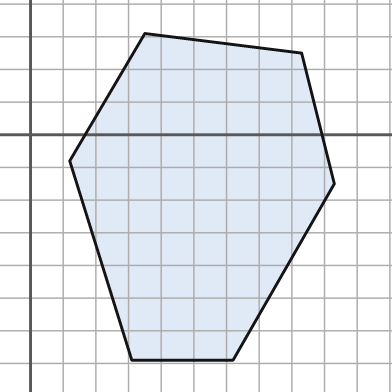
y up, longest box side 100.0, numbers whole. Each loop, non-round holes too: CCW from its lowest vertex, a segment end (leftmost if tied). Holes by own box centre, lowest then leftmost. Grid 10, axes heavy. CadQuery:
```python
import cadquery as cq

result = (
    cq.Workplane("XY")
    .moveTo(31.0, -69.0)
    .lineTo(62.0, -69.0)
    .lineTo(93.0, -15.0)
    .lineTo(83.0, 25.0)
    .lineTo(35.0, 31.0)
    .lineTo(12.0, -8.0)
    .close()
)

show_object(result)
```